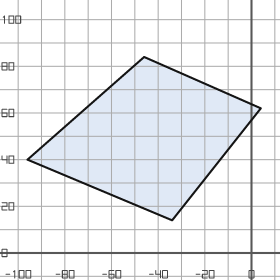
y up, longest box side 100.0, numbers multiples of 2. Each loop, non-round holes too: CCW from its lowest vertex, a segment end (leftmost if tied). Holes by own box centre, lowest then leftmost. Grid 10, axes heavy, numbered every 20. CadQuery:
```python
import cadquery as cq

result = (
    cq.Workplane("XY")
    .moveTo(-34.0, 14.0)
    .lineTo(4.0, 62.0)
    .lineTo(-46.0, 84.0)
    .lineTo(-96.0, 40.0)
    .close()
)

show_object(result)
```